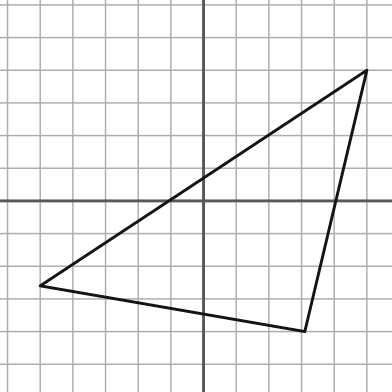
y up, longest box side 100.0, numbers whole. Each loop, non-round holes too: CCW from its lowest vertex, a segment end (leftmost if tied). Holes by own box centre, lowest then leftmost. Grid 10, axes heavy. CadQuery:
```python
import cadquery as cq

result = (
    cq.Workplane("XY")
    .moveTo(31.0, -40.0)
    .lineTo(50.0, 40.0)
    .lineTo(-50.0, -26.0)
    .close()
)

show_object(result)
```